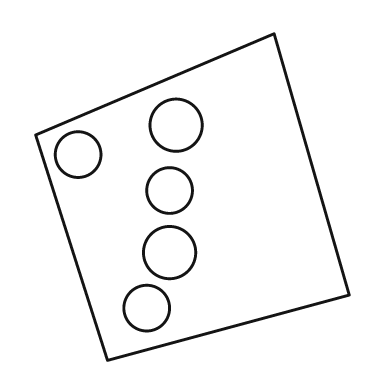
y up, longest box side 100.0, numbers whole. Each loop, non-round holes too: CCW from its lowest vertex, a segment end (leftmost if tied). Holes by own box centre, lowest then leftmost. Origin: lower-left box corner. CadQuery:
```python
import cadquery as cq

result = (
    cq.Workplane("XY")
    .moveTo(22.0, 0.0)
    .lineTo(96.0, 20.0)
    .lineTo(73.0, 100.0)
    .lineTo(0.0, 69.0)
    .close()
    .moveTo(34.0, 16.0)
    .circle(7.0)
    .moveTo(41.0, 33.0)
    .circle(8.0)
    .moveTo(41.0, 52.0)
    .circle(7.0)
    .moveTo(13.0, 63.0)
    .circle(7.0)
    .moveTo(43.0, 72.0)
    .circle(8.0)
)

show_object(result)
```